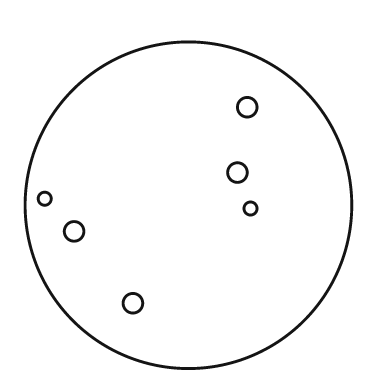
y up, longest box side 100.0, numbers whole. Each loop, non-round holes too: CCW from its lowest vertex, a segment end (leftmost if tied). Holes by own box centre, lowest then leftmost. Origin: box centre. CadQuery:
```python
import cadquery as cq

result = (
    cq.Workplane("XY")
    .moveTo(0.0, 0.0)
    .circle(50.0)
    .moveTo(-17.0, -30.0)
    .circle(3.0)
    .moveTo(-35.0, -8.0)
    .circle(3.0)
    .moveTo(19.0, -1.0)
    .circle(2.0)
    .moveTo(-44.0, 2.0)
    .circle(2.0)
    .moveTo(15.0, 10.0)
    .circle(3.0)
    .moveTo(18.0, 30.0)
    .circle(3.0)
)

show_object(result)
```